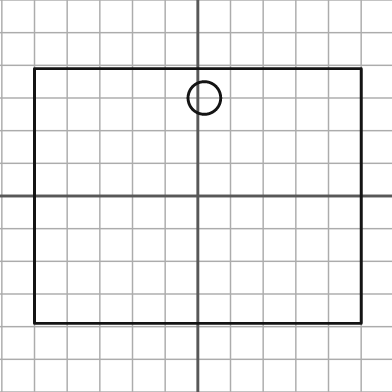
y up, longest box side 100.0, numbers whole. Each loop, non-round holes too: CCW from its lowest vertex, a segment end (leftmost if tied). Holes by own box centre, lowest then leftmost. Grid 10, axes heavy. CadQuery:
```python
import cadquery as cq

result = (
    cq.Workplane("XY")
    .moveTo(-50.0, -39.0)
    .lineTo(50.0, -39.0)
    .lineTo(50.0, 39.0)
    .lineTo(-50.0, 39.0)
    .close()
    .moveTo(2.0, 30.0)
    .circle(5.0)
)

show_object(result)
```